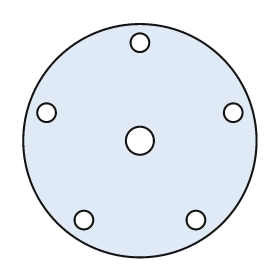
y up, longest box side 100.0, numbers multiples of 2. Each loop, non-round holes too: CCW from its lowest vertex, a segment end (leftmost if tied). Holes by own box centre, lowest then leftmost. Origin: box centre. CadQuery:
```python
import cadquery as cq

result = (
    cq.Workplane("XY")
    .moveTo(0.0, 0.0)
    .circle(50.0)
    .moveTo(-24.0, -34.0)
    .circle(4.0)
    .moveTo(24.0, -34.0)
    .circle(4.0)
    .moveTo(0.0, 0.0)
    .circle(6.0)
    .moveTo(-40.0, 12.0)
    .circle(4.0)
    .moveTo(40.0, 12.0)
    .circle(4.0)
    .moveTo(0.0, 42.0)
    .circle(4.0)
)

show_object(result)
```